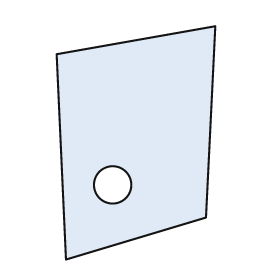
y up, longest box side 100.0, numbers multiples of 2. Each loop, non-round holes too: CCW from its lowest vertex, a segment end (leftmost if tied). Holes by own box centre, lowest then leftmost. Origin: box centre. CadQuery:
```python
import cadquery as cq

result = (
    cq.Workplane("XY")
    .moveTo(-30.0, -50.0)
    .lineTo(30.0, -32.0)
    .lineTo(34.0, 50.0)
    .lineTo(-34.0, 38.0)
    .close()
    .moveTo(-10.0, -18.0)
    .circle(8.0)
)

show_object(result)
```